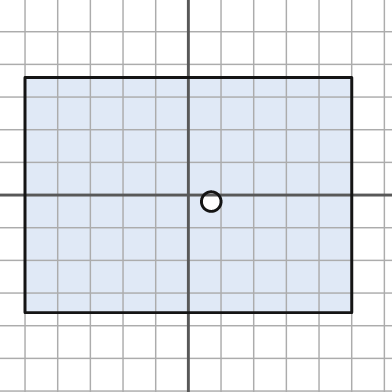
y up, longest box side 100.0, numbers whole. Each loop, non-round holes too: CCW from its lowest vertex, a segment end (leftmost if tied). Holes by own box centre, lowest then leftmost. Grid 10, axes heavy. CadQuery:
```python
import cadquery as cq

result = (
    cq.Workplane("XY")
    .moveTo(-50.0, -36.0)
    .lineTo(50.0, -36.0)
    .lineTo(50.0, 36.0)
    .lineTo(-50.0, 36.0)
    .close()
    .moveTo(7.0, -2.0)
    .circle(3.0)
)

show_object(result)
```